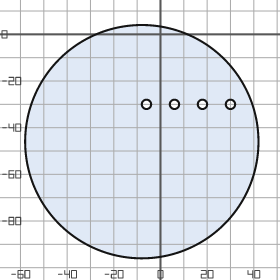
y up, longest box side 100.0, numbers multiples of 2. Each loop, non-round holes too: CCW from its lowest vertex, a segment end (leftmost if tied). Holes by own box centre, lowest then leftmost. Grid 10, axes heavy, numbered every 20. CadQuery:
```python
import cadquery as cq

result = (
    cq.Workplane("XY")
    .moveTo(-8.0, -46.0)
    .circle(50.0)
    .moveTo(-6.0, -30.0)
    .circle(2.0)
    .moveTo(6.0, -30.0)
    .circle(2.0)
    .moveTo(18.0, -30.0)
    .circle(2.0)
    .moveTo(30.0, -30.0)
    .circle(2.0)
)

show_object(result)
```